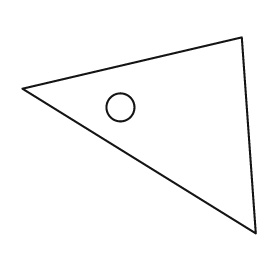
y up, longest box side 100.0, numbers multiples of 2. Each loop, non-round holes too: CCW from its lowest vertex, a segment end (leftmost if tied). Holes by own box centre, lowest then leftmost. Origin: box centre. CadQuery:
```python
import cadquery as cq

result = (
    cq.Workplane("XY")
    .moveTo(50.0, -42.0)
    .lineTo(44.0, 42.0)
    .lineTo(-50.0, 20.0)
    .close()
    .moveTo(-8.0, 12.0)
    .circle(6.0)
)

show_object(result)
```